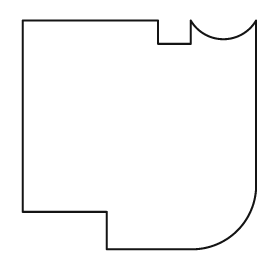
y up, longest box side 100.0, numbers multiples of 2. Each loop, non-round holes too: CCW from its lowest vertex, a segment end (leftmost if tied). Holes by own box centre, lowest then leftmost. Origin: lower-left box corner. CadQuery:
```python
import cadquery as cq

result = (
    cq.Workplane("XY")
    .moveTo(36.0, 0.0)
    .lineTo(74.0, 0.0)
    .threePointArc((92.0, 8.0), (100.0, 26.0))
    .lineTo(100.0, 98.0)
    .threePointArc((86.0, 90.0), (72.0, 98.0))
    .lineTo(72.0, 88.0)
    .lineTo(58.0, 88.0)
    .lineTo(58.0, 98.0)
    .lineTo(0.0, 98.0)
    .lineTo(0.0, 16.0)
    .lineTo(36.0, 16.0)
    .close()
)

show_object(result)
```